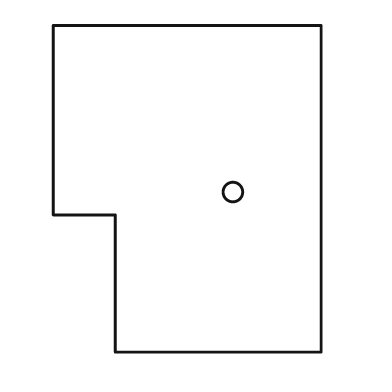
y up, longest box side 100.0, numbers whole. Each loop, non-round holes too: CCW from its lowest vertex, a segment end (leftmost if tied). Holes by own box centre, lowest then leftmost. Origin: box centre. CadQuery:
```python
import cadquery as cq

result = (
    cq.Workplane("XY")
    .moveTo(-22.0, -50.0)
    .lineTo(41.0, -50.0)
    .lineTo(41.0, 50.0)
    .lineTo(-41.0, 50.0)
    .lineTo(-41.0, -8.0)
    .lineTo(-22.0, -8.0)
    .close()
    .moveTo(14.0, -1.0)
    .circle(3.0)
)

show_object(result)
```